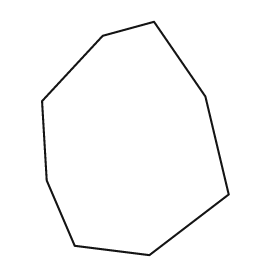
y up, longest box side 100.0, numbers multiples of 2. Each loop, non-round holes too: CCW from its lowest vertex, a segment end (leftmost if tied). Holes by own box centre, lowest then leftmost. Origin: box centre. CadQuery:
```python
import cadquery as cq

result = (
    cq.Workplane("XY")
    .moveTo(6.0, -50.0)
    .lineTo(40.0, -24.0)
    .lineTo(30.0, 18.0)
    .lineTo(8.0, 50.0)
    .lineTo(-14.0, 44.0)
    .lineTo(-40.0, 16.0)
    .lineTo(-38.0, -18.0)
    .lineTo(-26.0, -46.0)
    .close()
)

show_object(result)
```